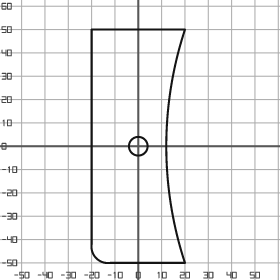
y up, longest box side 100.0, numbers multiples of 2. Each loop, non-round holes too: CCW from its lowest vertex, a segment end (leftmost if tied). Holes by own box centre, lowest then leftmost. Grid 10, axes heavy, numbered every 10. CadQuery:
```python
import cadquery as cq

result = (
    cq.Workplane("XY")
    .moveTo(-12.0, -50.0)
    .lineTo(20.0, -50.0)
    .threePointArc((12.0, 0.0), (20.0, 50.0))
    .lineTo(-20.0, 50.0)
    .lineTo(-20.0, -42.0)
    .threePointArc((-18.0, -48.0), (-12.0, -50.0))
    .close()
    .moveTo(0.0, 0.0)
    .circle(4.0)
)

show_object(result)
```